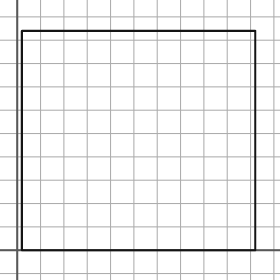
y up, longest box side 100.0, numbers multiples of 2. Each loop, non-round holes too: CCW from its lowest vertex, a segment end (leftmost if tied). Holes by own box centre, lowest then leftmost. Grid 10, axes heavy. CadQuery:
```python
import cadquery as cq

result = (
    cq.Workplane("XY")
    .moveTo(2.0, 0.0)
    .lineTo(102.0, 0.0)
    .lineTo(102.0, 94.0)
    .lineTo(2.0, 94.0)
    .close()
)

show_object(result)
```